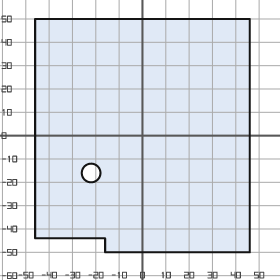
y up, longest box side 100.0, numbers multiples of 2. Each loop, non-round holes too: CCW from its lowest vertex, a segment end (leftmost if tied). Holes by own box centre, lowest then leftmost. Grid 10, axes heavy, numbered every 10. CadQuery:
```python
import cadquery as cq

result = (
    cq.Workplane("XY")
    .moveTo(-16.0, -50.0)
    .lineTo(46.0, -50.0)
    .lineTo(46.0, 50.0)
    .lineTo(-46.0, 50.0)
    .lineTo(-46.0, -44.0)
    .lineTo(-16.0, -44.0)
    .close()
    .moveTo(-22.0, -16.0)
    .circle(4.0)
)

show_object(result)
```